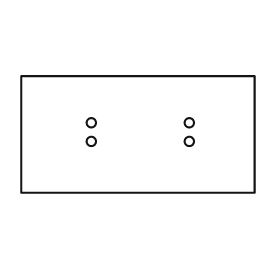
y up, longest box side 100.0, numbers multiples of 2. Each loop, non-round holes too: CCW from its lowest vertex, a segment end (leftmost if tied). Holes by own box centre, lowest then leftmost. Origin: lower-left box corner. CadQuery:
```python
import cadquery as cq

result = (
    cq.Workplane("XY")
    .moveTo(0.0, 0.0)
    .lineTo(100.0, 0.0)
    .lineTo(100.0, 50.0)
    .lineTo(0.0, 50.0)
    .close()
    .moveTo(30.0, 22.0)
    .circle(2.0)
    .moveTo(72.0, 22.0)
    .circle(2.0)
    .moveTo(30.0, 30.0)
    .circle(2.0)
    .moveTo(72.0, 30.0)
    .circle(2.0)
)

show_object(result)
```